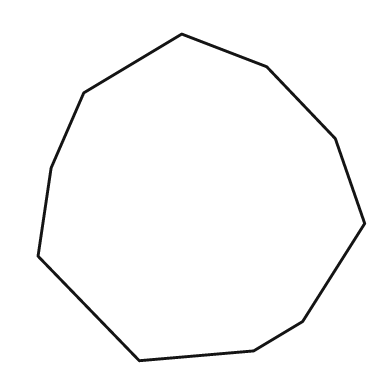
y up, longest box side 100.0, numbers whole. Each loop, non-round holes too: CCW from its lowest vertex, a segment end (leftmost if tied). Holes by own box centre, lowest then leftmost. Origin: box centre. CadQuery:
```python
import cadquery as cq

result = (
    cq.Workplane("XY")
    .moveTo(-19.0, -50.0)
    .lineTo(16.0, -47.0)
    .lineTo(31.0, -38.0)
    .lineTo(50.0, -8.0)
    .lineTo(41.0, 18.0)
    .lineTo(20.0, 40.0)
    .lineTo(-6.0, 50.0)
    .lineTo(-36.0, 32.0)
    .lineTo(-46.0, 9.0)
    .lineTo(-50.0, -18.0)
    .close()
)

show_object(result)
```